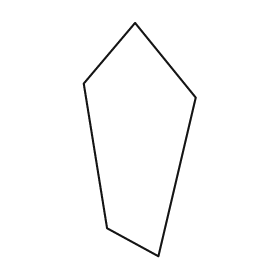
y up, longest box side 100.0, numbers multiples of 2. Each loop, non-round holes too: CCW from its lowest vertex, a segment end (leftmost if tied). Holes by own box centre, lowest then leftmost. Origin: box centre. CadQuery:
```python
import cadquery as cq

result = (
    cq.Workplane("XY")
    .moveTo(8.0, -50.0)
    .lineTo(24.0, 18.0)
    .lineTo(-2.0, 50.0)
    .lineTo(-24.0, 24.0)
    .lineTo(-14.0, -38.0)
    .close()
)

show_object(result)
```